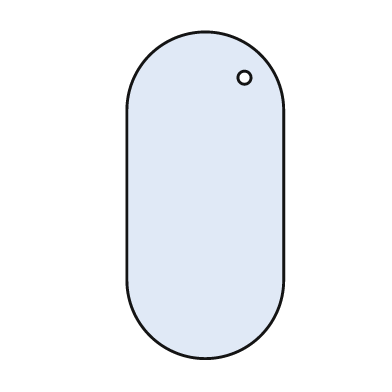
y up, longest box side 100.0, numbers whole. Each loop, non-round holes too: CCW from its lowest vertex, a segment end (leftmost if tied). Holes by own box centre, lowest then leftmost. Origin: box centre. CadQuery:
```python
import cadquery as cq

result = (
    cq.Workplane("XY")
    .moveTo(-24.0, -26.0)
    .threePointArc((0.0, -50.0), (24.0, -26.0))
    .lineTo(24.0, 26.0)
    .threePointArc((0.0, 50.0), (-24.0, 26.0))
    .close()
    .moveTo(12.0, 36.0)
    .circle(2.0)
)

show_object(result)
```